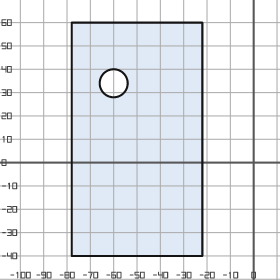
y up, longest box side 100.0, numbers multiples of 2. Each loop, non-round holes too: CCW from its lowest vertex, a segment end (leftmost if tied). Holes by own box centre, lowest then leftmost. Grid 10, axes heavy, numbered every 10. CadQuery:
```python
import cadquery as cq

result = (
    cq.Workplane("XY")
    .moveTo(-78.0, -40.0)
    .lineTo(-22.0, -40.0)
    .lineTo(-22.0, 60.0)
    .lineTo(-78.0, 60.0)
    .close()
    .moveTo(-60.0, 34.0)
    .circle(6.0)
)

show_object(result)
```